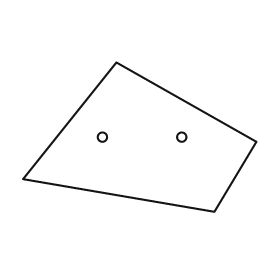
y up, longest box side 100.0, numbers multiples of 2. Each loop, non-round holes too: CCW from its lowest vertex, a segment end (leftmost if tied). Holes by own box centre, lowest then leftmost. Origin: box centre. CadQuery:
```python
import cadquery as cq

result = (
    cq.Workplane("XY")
    .moveTo(32.0, -32.0)
    .lineTo(50.0, -2.0)
    .lineTo(-10.0, 32.0)
    .lineTo(-50.0, -18.0)
    .close()
    .moveTo(-16.0, 0.0)
    .circle(2.0)
    .moveTo(18.0, 0.0)
    .circle(2.0)
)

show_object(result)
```